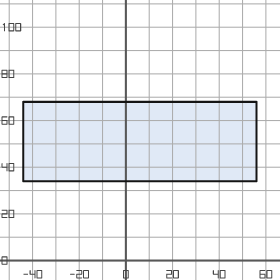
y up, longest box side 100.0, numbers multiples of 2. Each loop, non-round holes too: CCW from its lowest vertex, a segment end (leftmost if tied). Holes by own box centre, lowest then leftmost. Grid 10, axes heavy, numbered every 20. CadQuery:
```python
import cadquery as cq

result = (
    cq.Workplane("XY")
    .moveTo(-44.0, 34.0)
    .lineTo(56.0, 34.0)
    .lineTo(56.0, 68.0)
    .lineTo(-44.0, 68.0)
    .close()
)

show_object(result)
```